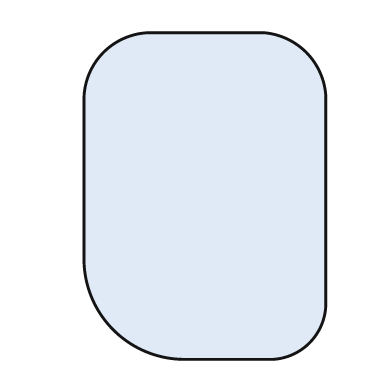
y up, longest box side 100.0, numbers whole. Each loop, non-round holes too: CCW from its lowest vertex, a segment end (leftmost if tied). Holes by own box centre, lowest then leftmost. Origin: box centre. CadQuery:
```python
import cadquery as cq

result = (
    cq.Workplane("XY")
    .moveTo(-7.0, -50.0)
    .lineTo(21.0, -50.0)
    .threePointArc((32.0, -45.0), (37.0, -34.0))
    .lineTo(37.0, 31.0)
    .threePointArc((31.0, 44.0), (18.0, 50.0))
    .lineTo(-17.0, 50.0)
    .threePointArc((-31.0, 44.0), (-37.0, 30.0))
    .lineTo(-37.0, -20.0)
    .threePointArc((-28.0, -41.0), (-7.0, -50.0))
    .close()
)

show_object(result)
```